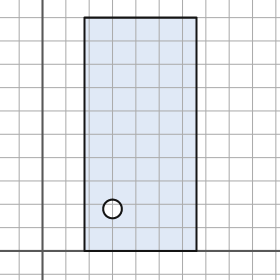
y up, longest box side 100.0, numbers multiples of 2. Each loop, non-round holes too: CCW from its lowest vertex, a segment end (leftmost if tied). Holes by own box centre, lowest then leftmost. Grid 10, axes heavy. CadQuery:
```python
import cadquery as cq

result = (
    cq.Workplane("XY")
    .moveTo(18.0, 0.0)
    .lineTo(66.0, 0.0)
    .lineTo(66.0, 100.0)
    .lineTo(18.0, 100.0)
    .close()
    .moveTo(30.0, 18.0)
    .circle(4.0)
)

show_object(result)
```